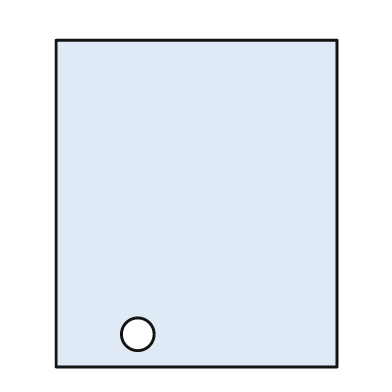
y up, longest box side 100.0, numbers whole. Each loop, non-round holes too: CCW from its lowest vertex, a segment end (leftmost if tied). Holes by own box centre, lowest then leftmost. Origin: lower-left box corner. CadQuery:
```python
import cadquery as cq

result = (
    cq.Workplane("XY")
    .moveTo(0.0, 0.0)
    .lineTo(86.0, 0.0)
    .lineTo(86.0, 100.0)
    .lineTo(0.0, 100.0)
    .close()
    .moveTo(25.0, 10.0)
    .circle(5.0)
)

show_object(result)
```